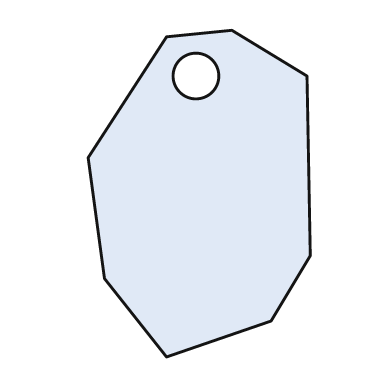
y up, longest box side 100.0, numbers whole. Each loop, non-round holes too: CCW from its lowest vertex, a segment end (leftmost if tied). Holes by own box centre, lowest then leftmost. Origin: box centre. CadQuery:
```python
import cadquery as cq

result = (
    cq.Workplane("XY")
    .moveTo(-10.0, -50.0)
    .lineTo(22.0, -39.0)
    .lineTo(34.0, -19.0)
    .lineTo(33.0, 36.0)
    .lineTo(10.0, 50.0)
    .lineTo(-10.0, 48.0)
    .lineTo(-34.0, 11.0)
    .lineTo(-29.0, -26.0)
    .close()
    .moveTo(-1.0, 36.0)
    .circle(7.0)
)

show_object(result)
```